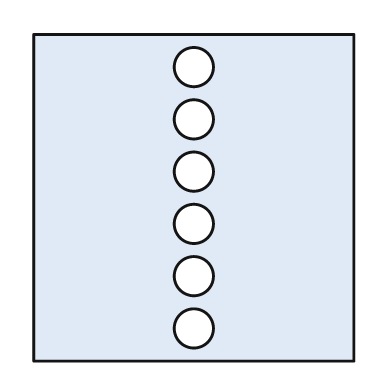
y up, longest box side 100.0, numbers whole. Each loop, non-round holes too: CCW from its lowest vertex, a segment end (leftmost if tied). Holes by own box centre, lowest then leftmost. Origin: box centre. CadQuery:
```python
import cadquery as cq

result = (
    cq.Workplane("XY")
    .moveTo(-49.0, -50.0)
    .lineTo(49.0, -50.0)
    .lineTo(49.0, 50.0)
    .lineTo(-49.0, 50.0)
    .close()
    .moveTo(0.0, -40.0)
    .circle(6.0)
    .moveTo(0.0, -24.0)
    .circle(6.0)
    .moveTo(0.0, -8.0)
    .circle(6.0)
    .moveTo(0.0, 8.0)
    .circle(6.0)
    .moveTo(0.0, 24.0)
    .circle(6.0)
    .moveTo(0.0, 40.0)
    .circle(6.0)
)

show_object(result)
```